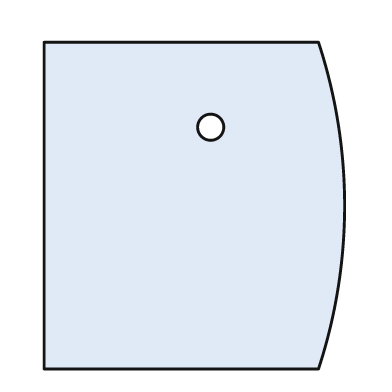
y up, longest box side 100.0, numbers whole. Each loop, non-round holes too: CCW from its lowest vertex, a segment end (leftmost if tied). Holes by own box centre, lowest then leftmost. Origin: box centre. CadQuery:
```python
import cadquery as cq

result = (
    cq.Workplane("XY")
    .moveTo(-46.0, -50.0)
    .lineTo(38.0, -50.0)
    .threePointArc((46.0, 0.0), (38.0, 50.0))
    .lineTo(-46.0, 50.0)
    .close()
    .moveTo(5.0, 24.0)
    .circle(4.0)
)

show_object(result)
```